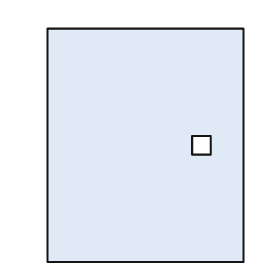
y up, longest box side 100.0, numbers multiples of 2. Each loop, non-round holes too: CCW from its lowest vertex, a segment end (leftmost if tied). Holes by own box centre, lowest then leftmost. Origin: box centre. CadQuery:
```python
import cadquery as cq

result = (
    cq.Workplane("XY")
    .moveTo(-42.0, -50.0)
    .lineTo(42.0, -50.0)
    .lineTo(42.0, 50.0)
    .lineTo(-42.0, 50.0)
    .close()
    .moveTo(20.0, -4.0)
    .lineTo(28.0, -4.0)
    .lineTo(28.0, 4.0)
    .lineTo(20.0, 4.0)
    .close()
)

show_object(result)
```